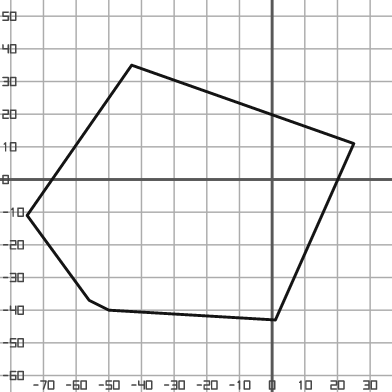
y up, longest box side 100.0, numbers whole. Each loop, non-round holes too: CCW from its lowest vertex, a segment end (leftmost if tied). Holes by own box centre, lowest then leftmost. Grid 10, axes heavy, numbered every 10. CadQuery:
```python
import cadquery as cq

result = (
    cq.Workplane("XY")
    .moveTo(1.0, -43.0)
    .lineTo(25.0, 11.0)
    .lineTo(-43.0, 35.0)
    .lineTo(-75.0, -11.0)
    .lineTo(-56.0, -37.0)
    .lineTo(-50.0, -40.0)
    .close()
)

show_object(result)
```